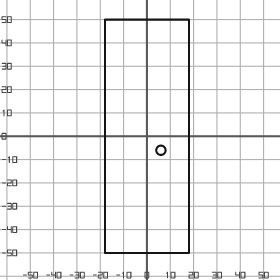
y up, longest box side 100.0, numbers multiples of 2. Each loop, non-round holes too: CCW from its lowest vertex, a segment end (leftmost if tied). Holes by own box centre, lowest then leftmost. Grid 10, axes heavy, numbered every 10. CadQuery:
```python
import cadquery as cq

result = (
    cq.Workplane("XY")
    .moveTo(-18.0, -50.0)
    .lineTo(18.0, -50.0)
    .lineTo(18.0, 50.0)
    .lineTo(-18.0, 50.0)
    .close()
    .moveTo(6.0, -6.0)
    .circle(2.0)
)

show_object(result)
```